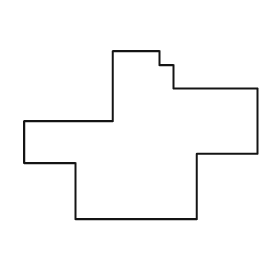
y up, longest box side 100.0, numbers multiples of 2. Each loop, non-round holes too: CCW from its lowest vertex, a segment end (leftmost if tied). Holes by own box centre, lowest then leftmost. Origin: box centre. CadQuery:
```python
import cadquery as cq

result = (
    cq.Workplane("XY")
    .moveTo(-28.0, -36.0)
    .lineTo(24.0, -36.0)
    .lineTo(24.0, -8.0)
    .lineTo(50.0, -8.0)
    .lineTo(50.0, 20.0)
    .lineTo(14.0, 20.0)
    .lineTo(14.0, 30.0)
    .lineTo(8.0, 30.0)
    .lineTo(8.0, 36.0)
    .lineTo(-12.0, 36.0)
    .lineTo(-12.0, 6.0)
    .lineTo(-50.0, 6.0)
    .lineTo(-50.0, -12.0)
    .lineTo(-28.0, -12.0)
    .close()
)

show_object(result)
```